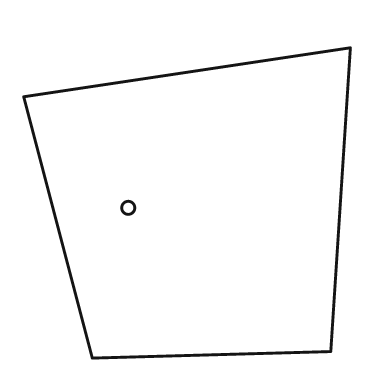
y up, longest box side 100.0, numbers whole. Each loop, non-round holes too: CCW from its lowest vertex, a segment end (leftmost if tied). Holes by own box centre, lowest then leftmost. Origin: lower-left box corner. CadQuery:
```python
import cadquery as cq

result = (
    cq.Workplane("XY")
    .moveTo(21.0, 0.0)
    .lineTo(94.0, 2.0)
    .lineTo(100.0, 95.0)
    .lineTo(0.0, 80.0)
    .close()
    .moveTo(32.0, 46.0)
    .circle(2.0)
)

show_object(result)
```